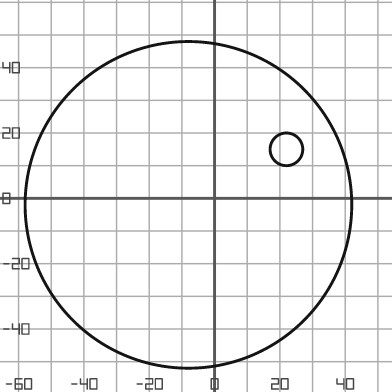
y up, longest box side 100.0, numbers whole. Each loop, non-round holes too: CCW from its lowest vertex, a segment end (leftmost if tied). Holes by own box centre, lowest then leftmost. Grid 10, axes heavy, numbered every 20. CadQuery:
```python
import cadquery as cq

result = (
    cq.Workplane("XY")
    .moveTo(-8.0, -2.0)
    .circle(50.0)
    .moveTo(22.0, 15.0)
    .circle(5.0)
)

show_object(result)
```